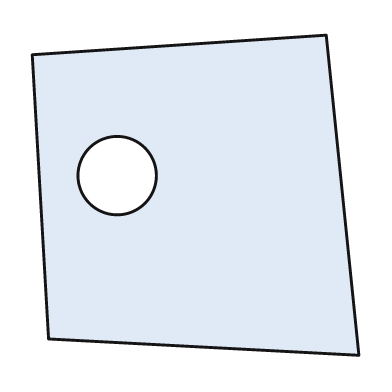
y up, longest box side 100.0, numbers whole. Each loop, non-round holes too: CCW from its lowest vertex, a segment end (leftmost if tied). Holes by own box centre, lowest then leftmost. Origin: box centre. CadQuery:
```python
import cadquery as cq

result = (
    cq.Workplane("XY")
    .moveTo(50.0, -49.0)
    .lineTo(40.0, 49.0)
    .lineTo(-50.0, 43.0)
    .lineTo(-45.0, -44.0)
    .close()
    .moveTo(-24.0, 6.0)
    .circle(12.0)
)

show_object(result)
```